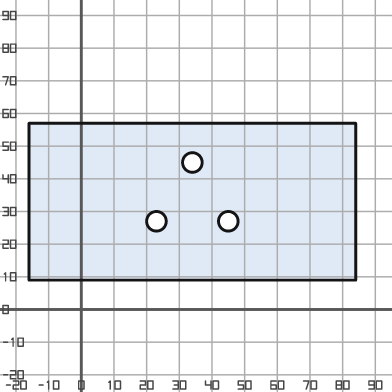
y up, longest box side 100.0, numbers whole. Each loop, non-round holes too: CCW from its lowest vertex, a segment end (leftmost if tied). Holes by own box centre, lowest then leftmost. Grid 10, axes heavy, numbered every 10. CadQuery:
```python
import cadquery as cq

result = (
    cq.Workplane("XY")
    .moveTo(-16.0, 9.0)
    .lineTo(84.0, 9.0)
    .lineTo(84.0, 57.0)
    .lineTo(-16.0, 57.0)
    .close()
    .moveTo(23.0, 27.0)
    .circle(3.0)
    .moveTo(45.0, 27.0)
    .circle(3.0)
    .moveTo(34.0, 45.0)
    .circle(3.0)
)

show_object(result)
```